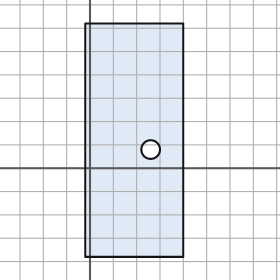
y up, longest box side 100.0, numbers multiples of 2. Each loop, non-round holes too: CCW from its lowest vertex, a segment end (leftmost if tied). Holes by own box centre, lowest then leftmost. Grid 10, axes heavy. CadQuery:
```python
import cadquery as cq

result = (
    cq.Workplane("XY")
    .moveTo(-2.0, -38.0)
    .lineTo(40.0, -38.0)
    .lineTo(40.0, 62.0)
    .lineTo(-2.0, 62.0)
    .close()
    .moveTo(26.0, 8.0)
    .circle(4.0)
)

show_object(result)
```